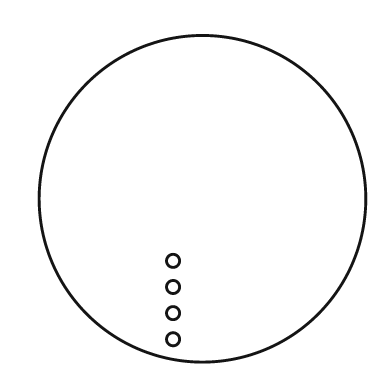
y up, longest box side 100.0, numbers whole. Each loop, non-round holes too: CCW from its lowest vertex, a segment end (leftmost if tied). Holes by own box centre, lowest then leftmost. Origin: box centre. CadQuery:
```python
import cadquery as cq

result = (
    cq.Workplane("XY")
    .moveTo(0.0, 0.0)
    .circle(50.0)
    .moveTo(-9.0, -43.0)
    .circle(2.0)
    .moveTo(-9.0, -35.0)
    .circle(2.0)
    .moveTo(-9.0, -27.0)
    .circle(2.0)
    .moveTo(-9.0, -19.0)
    .circle(2.0)
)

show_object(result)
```